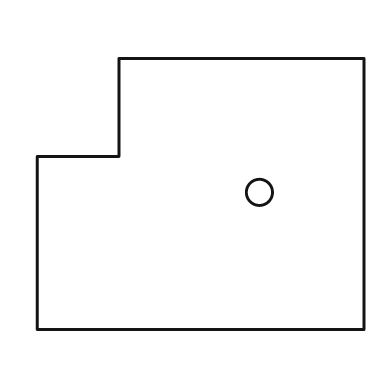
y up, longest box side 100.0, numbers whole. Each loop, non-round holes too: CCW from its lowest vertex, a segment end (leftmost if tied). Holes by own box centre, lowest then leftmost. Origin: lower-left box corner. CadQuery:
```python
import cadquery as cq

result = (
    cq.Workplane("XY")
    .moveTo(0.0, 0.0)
    .lineTo(100.0, 0.0)
    .lineTo(100.0, 83.0)
    .lineTo(25.0, 83.0)
    .lineTo(25.0, 53.0)
    .lineTo(0.0, 53.0)
    .close()
    .moveTo(68.0, 42.0)
    .circle(4.0)
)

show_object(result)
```